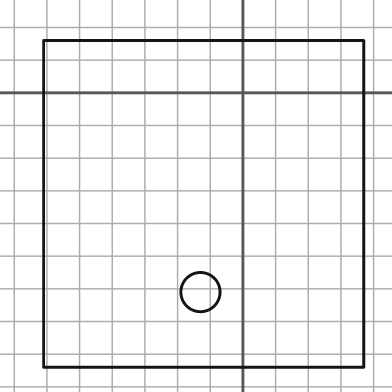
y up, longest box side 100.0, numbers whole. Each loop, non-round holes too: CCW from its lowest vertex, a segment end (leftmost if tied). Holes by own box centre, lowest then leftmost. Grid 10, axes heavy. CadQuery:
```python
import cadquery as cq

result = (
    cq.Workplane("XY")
    .moveTo(-61.0, -84.0)
    .lineTo(37.0, -84.0)
    .lineTo(37.0, 16.0)
    .lineTo(-61.0, 16.0)
    .close()
    .moveTo(-13.0, -61.0)
    .circle(6.0)
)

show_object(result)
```